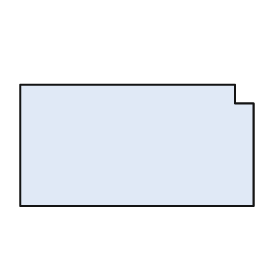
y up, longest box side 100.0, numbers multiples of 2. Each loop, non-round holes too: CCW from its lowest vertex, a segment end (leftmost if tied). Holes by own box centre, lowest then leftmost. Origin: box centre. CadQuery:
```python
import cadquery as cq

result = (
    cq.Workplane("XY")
    .moveTo(-50.0, -26.0)
    .lineTo(50.0, -26.0)
    .lineTo(50.0, 18.0)
    .lineTo(42.0, 18.0)
    .lineTo(42.0, 26.0)
    .lineTo(-50.0, 26.0)
    .close()
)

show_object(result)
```